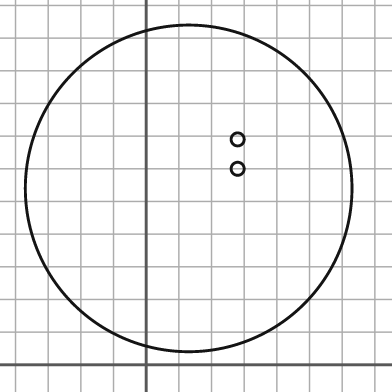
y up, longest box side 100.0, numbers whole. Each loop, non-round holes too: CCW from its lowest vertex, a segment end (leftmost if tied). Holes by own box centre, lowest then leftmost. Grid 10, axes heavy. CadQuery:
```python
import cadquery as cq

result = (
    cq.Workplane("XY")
    .moveTo(13.0, 54.0)
    .circle(50.0)
    .moveTo(28.0, 60.0)
    .circle(2.0)
    .moveTo(28.0, 69.0)
    .circle(2.0)
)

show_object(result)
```